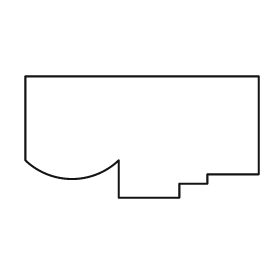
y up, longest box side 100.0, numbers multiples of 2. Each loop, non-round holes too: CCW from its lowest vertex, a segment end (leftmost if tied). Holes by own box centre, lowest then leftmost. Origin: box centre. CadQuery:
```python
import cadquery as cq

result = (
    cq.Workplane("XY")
    .moveTo(-10.0, -26.0)
    .lineTo(16.0, -26.0)
    .lineTo(16.0, -20.0)
    .lineTo(28.0, -20.0)
    .lineTo(28.0, -16.0)
    .lineTo(50.0, -16.0)
    .lineTo(50.0, 26.0)
    .lineTo(-50.0, 26.0)
    .lineTo(-50.0, -10.0)
    .threePointArc((-30.0, -18.0), (-10.0, -10.0))
    .close()
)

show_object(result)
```